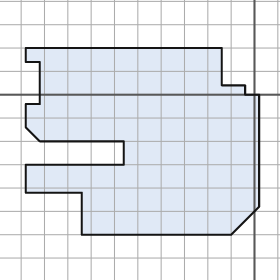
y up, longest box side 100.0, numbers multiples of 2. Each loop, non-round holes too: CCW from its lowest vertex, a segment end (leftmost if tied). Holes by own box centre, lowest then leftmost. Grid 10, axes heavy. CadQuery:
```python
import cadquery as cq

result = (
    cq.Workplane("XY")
    .moveTo(-74.0, -60.0)
    .lineTo(-10.0, -60.0)
    .lineTo(2.0, -48.0)
    .lineTo(2.0, 0.0)
    .lineTo(-4.0, 0.0)
    .lineTo(-4.0, 4.0)
    .lineTo(-14.0, 4.0)
    .lineTo(-14.0, 20.0)
    .lineTo(-98.0, 20.0)
    .lineTo(-98.0, 14.0)
    .lineTo(-92.0, 14.0)
    .lineTo(-92.0, -4.0)
    .lineTo(-98.0, -4.0)
    .lineTo(-98.0, -14.0)
    .lineTo(-92.0, -20.0)
    .lineTo(-56.0, -20.0)
    .lineTo(-56.0, -30.0)
    .lineTo(-98.0, -30.0)
    .lineTo(-98.0, -42.0)
    .lineTo(-74.0, -42.0)
    .close()
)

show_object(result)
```